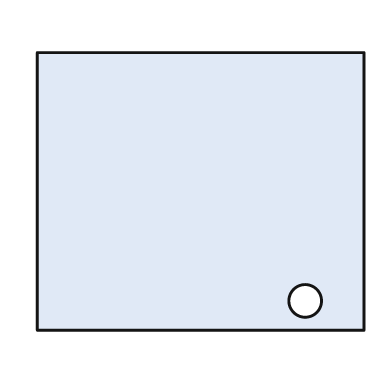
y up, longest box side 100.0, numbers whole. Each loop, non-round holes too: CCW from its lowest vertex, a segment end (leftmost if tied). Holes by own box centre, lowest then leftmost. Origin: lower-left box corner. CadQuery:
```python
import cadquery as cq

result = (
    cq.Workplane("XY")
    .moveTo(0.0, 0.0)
    .lineTo(100.0, 0.0)
    .lineTo(100.0, 85.0)
    .lineTo(0.0, 85.0)
    .close()
    .moveTo(82.0, 9.0)
    .circle(5.0)
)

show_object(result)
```